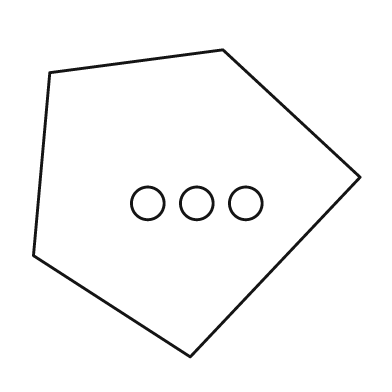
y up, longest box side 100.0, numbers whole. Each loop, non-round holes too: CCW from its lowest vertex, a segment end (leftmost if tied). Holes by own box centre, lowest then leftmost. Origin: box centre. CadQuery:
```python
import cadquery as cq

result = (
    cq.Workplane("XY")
    .moveTo(-2.0, -47.0)
    .lineTo(50.0, 8.0)
    .lineTo(8.0, 47.0)
    .lineTo(-45.0, 40.0)
    .lineTo(-50.0, -16.0)
    .close()
    .moveTo(-15.0, 0.0)
    .circle(5.0)
    .moveTo(0.0, 0.0)
    .circle(5.0)
    .moveTo(15.0, 0.0)
    .circle(5.0)
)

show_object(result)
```